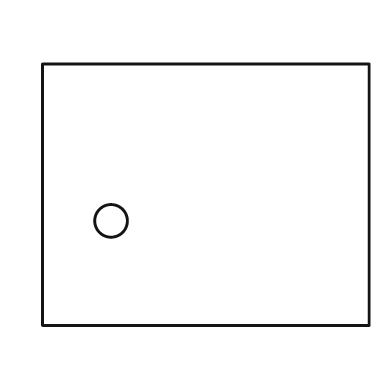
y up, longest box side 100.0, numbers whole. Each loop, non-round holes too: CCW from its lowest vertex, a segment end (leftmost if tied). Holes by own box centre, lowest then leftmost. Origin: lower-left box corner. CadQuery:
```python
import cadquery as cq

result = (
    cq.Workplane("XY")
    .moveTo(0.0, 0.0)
    .lineTo(100.0, 0.0)
    .lineTo(100.0, 80.0)
    .lineTo(0.0, 80.0)
    .close()
    .moveTo(21.0, 32.0)
    .circle(5.0)
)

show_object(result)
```